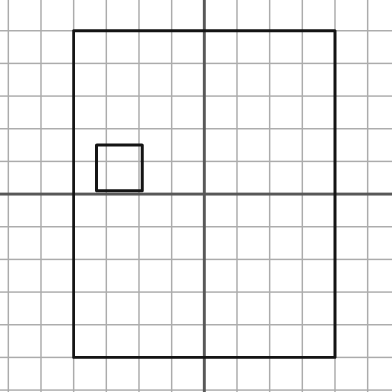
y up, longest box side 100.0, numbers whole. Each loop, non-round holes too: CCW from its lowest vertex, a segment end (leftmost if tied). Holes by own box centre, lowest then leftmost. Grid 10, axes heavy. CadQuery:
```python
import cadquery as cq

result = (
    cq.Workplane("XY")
    .moveTo(-40.0, -50.0)
    .lineTo(40.0, -50.0)
    .lineTo(40.0, 50.0)
    .lineTo(-40.0, 50.0)
    .close()
    .moveTo(-33.0, 1.0)
    .lineTo(-19.0, 1.0)
    .lineTo(-19.0, 15.0)
    .lineTo(-33.0, 15.0)
    .close()
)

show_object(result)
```